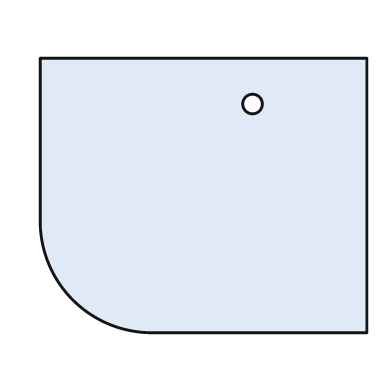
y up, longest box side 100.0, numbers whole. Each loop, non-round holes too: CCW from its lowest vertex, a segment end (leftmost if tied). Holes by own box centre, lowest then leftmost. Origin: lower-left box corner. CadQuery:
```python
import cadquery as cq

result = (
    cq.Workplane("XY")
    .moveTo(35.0, 0.0)
    .lineTo(100.0, 0.0)
    .lineTo(100.0, 84.0)
    .lineTo(0.0, 84.0)
    .lineTo(0.0, 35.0)
    .threePointArc((10.0, 10.0), (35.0, 0.0))
    .close()
    .moveTo(65.0, 70.0)
    .circle(3.0)
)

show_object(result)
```